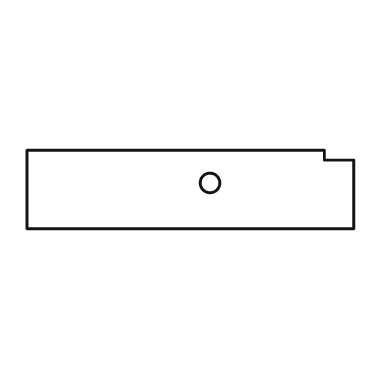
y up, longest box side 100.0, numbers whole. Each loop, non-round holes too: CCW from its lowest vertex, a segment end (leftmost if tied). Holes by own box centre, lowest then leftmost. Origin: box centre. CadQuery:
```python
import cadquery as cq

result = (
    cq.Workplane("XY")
    .moveTo(-50.0, -12.0)
    .lineTo(50.0, -12.0)
    .lineTo(50.0, 9.0)
    .lineTo(41.0, 9.0)
    .lineTo(41.0, 12.0)
    .lineTo(-50.0, 12.0)
    .close()
    .moveTo(6.0, 2.0)
    .circle(3.0)
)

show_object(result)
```